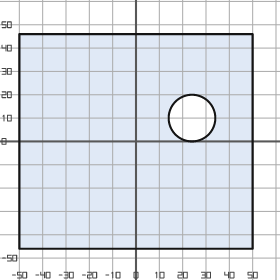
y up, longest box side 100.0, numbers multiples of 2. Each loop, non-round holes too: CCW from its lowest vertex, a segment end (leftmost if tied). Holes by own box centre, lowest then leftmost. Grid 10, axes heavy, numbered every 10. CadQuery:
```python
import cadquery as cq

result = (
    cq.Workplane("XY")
    .moveTo(-50.0, -46.0)
    .lineTo(50.0, -46.0)
    .lineTo(50.0, 46.0)
    .lineTo(-50.0, 46.0)
    .close()
    .moveTo(24.0, 10.0)
    .circle(10.0)
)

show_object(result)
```